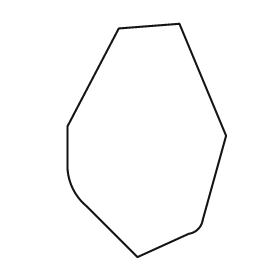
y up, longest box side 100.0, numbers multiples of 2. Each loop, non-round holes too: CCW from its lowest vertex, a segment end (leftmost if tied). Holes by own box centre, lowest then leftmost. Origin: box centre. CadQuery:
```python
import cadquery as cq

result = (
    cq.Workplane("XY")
    .moveTo(-4.0, -50.0)
    .lineTo(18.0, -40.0)
    .threePointArc((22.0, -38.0), (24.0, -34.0))
    .lineTo(34.0, 2.0)
    .lineTo(14.0, 50.0)
    .lineTo(-12.0, 48.0)
    .lineTo(-34.0, 6.0)
    .lineTo(-34.0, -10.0)
    .threePointArc((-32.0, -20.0), (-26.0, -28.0))
    .close()
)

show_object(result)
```